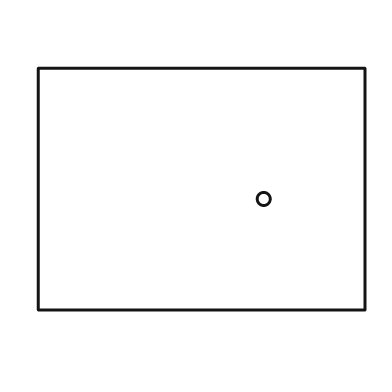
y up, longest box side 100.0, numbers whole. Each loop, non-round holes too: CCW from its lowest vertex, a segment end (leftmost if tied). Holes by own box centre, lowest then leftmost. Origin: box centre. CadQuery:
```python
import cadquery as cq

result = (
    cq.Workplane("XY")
    .moveTo(-50.0, -37.0)
    .lineTo(50.0, -37.0)
    .lineTo(50.0, 37.0)
    .lineTo(-50.0, 37.0)
    .close()
    .moveTo(19.0, -3.0)
    .circle(2.0)
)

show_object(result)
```